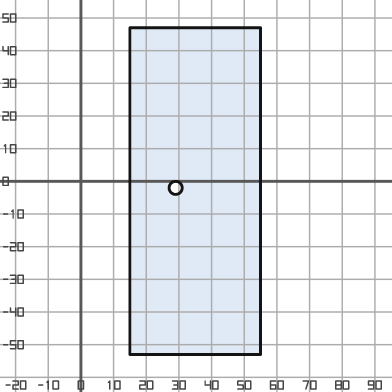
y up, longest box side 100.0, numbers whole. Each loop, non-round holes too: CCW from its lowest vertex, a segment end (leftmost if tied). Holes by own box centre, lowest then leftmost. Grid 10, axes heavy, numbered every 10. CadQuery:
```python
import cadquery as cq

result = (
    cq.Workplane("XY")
    .moveTo(15.0, -53.0)
    .lineTo(55.0, -53.0)
    .lineTo(55.0, 47.0)
    .lineTo(15.0, 47.0)
    .close()
    .moveTo(29.0, -2.0)
    .circle(2.0)
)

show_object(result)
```